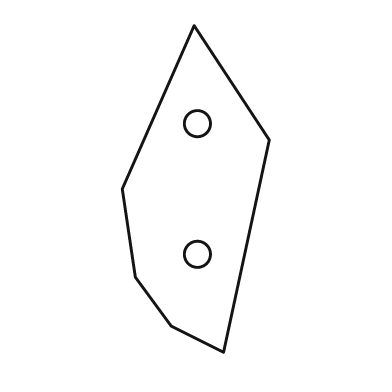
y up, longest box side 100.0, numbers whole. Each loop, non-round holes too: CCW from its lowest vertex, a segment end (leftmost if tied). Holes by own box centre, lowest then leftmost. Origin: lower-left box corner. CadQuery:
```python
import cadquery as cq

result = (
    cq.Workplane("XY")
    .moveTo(31.0, 0.0)
    .lineTo(45.0, 65.0)
    .lineTo(22.0, 100.0)
    .lineTo(0.0, 50.0)
    .lineTo(4.0, 23.0)
    .lineTo(15.0, 8.0)
    .close()
    .moveTo(23.0, 30.0)
    .circle(4.0)
    .moveTo(23.0, 70.0)
    .circle(4.0)
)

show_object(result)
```